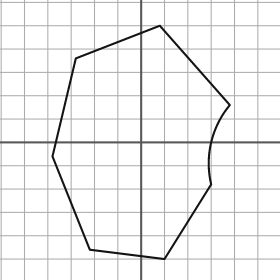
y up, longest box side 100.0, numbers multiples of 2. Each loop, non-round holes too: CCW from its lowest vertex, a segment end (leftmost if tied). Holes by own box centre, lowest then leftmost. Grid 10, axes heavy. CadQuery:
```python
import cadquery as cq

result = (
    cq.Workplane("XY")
    .moveTo(10.0, -50.0)
    .lineTo(30.0, -18.0)
    .threePointArc((30.0, 0.0), (38.0, 16.0))
    .lineTo(8.0, 50.0)
    .lineTo(-28.0, 36.0)
    .lineTo(-38.0, -6.0)
    .lineTo(-22.0, -46.0)
    .close()
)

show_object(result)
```